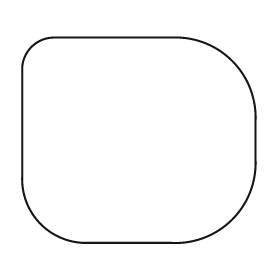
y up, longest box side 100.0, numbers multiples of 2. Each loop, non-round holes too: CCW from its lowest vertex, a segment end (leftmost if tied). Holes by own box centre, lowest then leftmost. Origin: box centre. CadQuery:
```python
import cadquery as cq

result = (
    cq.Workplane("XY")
    .moveTo(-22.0, -44.0)
    .lineTo(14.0, -44.0)
    .threePointArc((40.0, -34.0), (50.0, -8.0))
    .lineTo(50.0, 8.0)
    .threePointArc((40.0, 34.0), (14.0, 44.0))
    .lineTo(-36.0, 44.0)
    .threePointArc((-46.0, 40.0), (-50.0, 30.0))
    .lineTo(-50.0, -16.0)
    .threePointArc((-42.0, -36.0), (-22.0, -44.0))
    .close()
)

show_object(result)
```